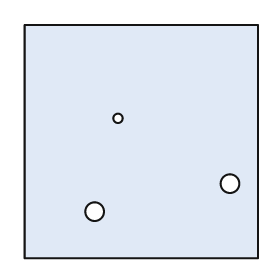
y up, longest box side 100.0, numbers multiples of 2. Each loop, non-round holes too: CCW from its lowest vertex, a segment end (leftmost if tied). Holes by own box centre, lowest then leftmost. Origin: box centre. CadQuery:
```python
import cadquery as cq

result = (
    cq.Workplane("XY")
    .moveTo(-50.0, -50.0)
    .lineTo(50.0, -50.0)
    .lineTo(50.0, 50.0)
    .lineTo(-50.0, 50.0)
    .close()
    .moveTo(-20.0, -30.0)
    .circle(4.0)
    .moveTo(38.0, -18.0)
    .circle(4.0)
    .moveTo(-10.0, 10.0)
    .circle(2.0)
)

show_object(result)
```